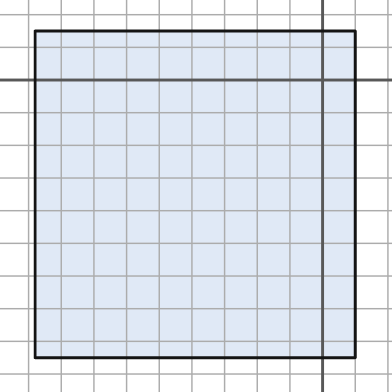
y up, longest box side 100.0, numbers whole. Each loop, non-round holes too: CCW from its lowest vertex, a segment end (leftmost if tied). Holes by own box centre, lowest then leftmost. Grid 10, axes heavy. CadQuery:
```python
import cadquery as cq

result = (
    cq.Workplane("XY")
    .moveTo(-88.0, -85.0)
    .lineTo(10.0, -85.0)
    .lineTo(10.0, 15.0)
    .lineTo(-88.0, 15.0)
    .close()
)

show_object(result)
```